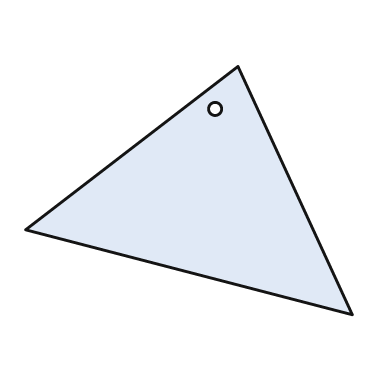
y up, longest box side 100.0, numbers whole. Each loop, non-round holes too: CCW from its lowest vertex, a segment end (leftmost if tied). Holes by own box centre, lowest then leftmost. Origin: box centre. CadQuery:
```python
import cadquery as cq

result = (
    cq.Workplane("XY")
    .moveTo(50.0, -38.0)
    .lineTo(15.0, 38.0)
    .lineTo(-50.0, -12.0)
    .close()
    .moveTo(8.0, 25.0)
    .circle(2.0)
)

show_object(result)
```